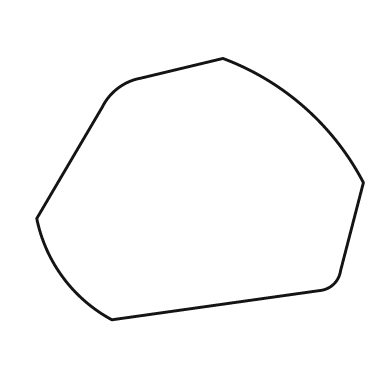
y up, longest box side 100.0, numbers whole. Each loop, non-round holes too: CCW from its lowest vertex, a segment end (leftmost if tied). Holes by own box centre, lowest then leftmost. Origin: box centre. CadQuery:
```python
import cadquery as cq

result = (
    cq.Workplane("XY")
    .moveTo(-27.0, -40.0)
    .lineTo(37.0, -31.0)
    .threePointArc((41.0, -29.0), (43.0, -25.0))
    .lineTo(50.0, 2.0)
    .threePointArc((32.0, 25.0), (7.0, 40.0))
    .lineTo(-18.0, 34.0)
    .threePointArc((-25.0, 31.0), (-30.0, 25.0))
    .lineTo(-50.0, -9.0)
    .threePointArc((-42.0, -27.0), (-27.0, -40.0))
    .close()
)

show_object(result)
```